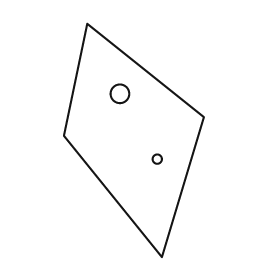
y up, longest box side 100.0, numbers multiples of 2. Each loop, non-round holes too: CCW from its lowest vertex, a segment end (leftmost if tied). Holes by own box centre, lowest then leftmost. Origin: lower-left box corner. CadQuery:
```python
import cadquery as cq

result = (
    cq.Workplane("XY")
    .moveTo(42.0, 0.0)
    .lineTo(60.0, 60.0)
    .lineTo(10.0, 100.0)
    .lineTo(0.0, 52.0)
    .close()
    .moveTo(40.0, 42.0)
    .circle(2.0)
    .moveTo(24.0, 70.0)
    .circle(4.0)
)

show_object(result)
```